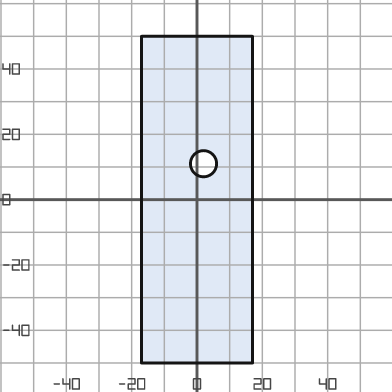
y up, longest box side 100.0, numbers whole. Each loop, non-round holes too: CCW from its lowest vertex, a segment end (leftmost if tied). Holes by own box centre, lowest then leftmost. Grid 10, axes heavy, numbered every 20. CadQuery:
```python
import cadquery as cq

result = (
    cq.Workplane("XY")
    .moveTo(-17.0, -50.0)
    .lineTo(17.0, -50.0)
    .lineTo(17.0, 50.0)
    .lineTo(-17.0, 50.0)
    .close()
    .moveTo(2.0, 11.0)
    .circle(4.0)
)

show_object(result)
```